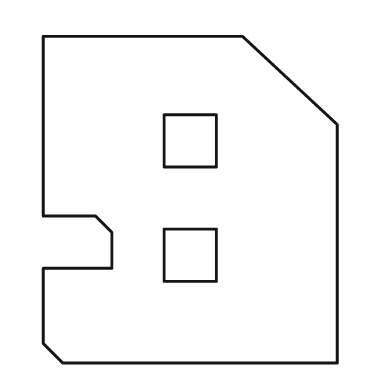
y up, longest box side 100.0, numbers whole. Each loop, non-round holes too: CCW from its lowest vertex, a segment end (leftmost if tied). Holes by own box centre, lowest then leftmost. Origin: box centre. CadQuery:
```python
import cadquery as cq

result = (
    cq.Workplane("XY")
    .moveTo(-39.0, -50.0)
    .lineTo(45.0, -50.0)
    .lineTo(45.0, 23.0)
    .lineTo(16.0, 50.0)
    .lineTo(-45.0, 50.0)
    .lineTo(-45.0, -5.0)
    .lineTo(-29.0, -5.0)
    .lineTo(-24.0, -10.0)
    .lineTo(-24.0, -21.0)
    .lineTo(-45.0, -21.0)
    .lineTo(-45.0, -44.0)
    .close()
    .moveTo(-8.0, -25.0)
    .lineTo(8.0, -25.0)
    .lineTo(8.0, -9.0)
    .lineTo(-8.0, -9.0)
    .close()
    .moveTo(-8.0, 10.0)
    .lineTo(8.0, 10.0)
    .lineTo(8.0, 26.0)
    .lineTo(-8.0, 26.0)
    .close()
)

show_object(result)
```